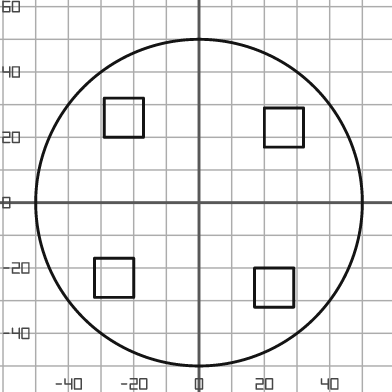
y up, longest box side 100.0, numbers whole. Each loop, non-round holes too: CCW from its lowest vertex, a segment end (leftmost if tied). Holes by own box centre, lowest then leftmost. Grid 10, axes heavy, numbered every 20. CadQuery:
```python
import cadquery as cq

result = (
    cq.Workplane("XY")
    .moveTo(0.0, 0.0)
    .circle(50.0)
    .moveTo(17.0, -32.0)
    .lineTo(29.0, -32.0)
    .lineTo(29.0, -20.0)
    .lineTo(17.0, -20.0)
    .close()
    .moveTo(-32.0, -29.0)
    .lineTo(-20.0, -29.0)
    .lineTo(-20.0, -17.0)
    .lineTo(-32.0, -17.0)
    .close()
    .moveTo(20.0, 17.0)
    .lineTo(32.0, 17.0)
    .lineTo(32.0, 29.0)
    .lineTo(20.0, 29.0)
    .close()
    .moveTo(-29.0, 20.0)
    .lineTo(-17.0, 20.0)
    .lineTo(-17.0, 32.0)
    .lineTo(-29.0, 32.0)
    .close()
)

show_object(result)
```